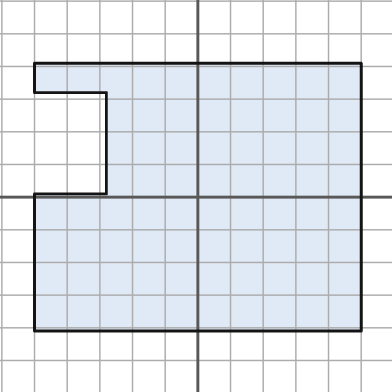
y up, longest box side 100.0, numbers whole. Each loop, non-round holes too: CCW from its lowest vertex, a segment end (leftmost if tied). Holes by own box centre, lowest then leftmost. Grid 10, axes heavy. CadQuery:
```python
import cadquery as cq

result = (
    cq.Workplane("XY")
    .moveTo(-50.0, -41.0)
    .lineTo(50.0, -41.0)
    .lineTo(50.0, 41.0)
    .lineTo(-50.0, 41.0)
    .lineTo(-50.0, 32.0)
    .lineTo(-28.0, 32.0)
    .lineTo(-28.0, 1.0)
    .lineTo(-50.0, 1.0)
    .close()
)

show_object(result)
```